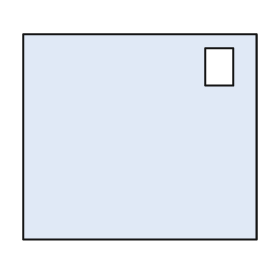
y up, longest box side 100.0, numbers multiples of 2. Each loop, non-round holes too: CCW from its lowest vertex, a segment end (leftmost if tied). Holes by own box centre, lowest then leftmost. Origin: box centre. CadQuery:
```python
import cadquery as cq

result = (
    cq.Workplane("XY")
    .moveTo(-50.0, -44.0)
    .lineTo(50.0, -44.0)
    .lineTo(50.0, 44.0)
    .lineTo(-50.0, 44.0)
    .close()
    .moveTo(28.0, 22.0)
    .lineTo(40.0, 22.0)
    .lineTo(40.0, 38.0)
    .lineTo(28.0, 38.0)
    .close()
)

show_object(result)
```